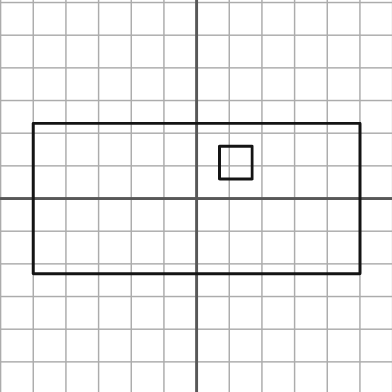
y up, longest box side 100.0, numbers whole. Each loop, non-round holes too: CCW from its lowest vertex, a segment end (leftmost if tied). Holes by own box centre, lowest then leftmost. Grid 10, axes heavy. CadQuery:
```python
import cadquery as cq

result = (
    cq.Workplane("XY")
    .moveTo(-50.0, -23.0)
    .lineTo(50.0, -23.0)
    .lineTo(50.0, 23.0)
    .lineTo(-50.0, 23.0)
    .close()
    .moveTo(7.0, 6.0)
    .lineTo(17.0, 6.0)
    .lineTo(17.0, 16.0)
    .lineTo(7.0, 16.0)
    .close()
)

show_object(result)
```